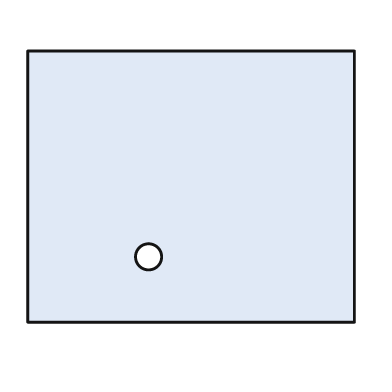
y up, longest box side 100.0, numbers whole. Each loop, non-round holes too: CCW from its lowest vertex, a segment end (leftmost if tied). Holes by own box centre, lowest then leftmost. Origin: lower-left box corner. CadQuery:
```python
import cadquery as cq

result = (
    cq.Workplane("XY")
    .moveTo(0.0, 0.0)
    .lineTo(100.0, 0.0)
    .lineTo(100.0, 83.0)
    .lineTo(0.0, 83.0)
    .close()
    .moveTo(37.0, 20.0)
    .circle(4.0)
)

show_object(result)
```